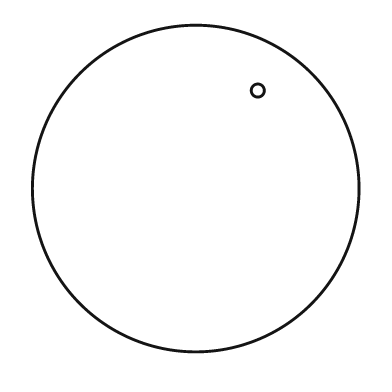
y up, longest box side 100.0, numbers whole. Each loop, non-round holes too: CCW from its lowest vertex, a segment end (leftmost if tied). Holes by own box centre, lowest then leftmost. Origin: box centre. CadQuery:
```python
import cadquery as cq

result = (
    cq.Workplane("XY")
    .moveTo(0.0, 0.0)
    .circle(50.0)
    .moveTo(19.0, 30.0)
    .circle(2.0)
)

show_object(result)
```